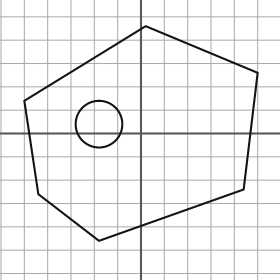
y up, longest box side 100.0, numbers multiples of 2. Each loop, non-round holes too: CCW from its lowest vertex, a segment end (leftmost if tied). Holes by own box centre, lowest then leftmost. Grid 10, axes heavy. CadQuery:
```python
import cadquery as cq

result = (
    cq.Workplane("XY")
    .moveTo(-18.0, -46.0)
    .lineTo(44.0, -24.0)
    .lineTo(50.0, 26.0)
    .lineTo(2.0, 46.0)
    .lineTo(-50.0, 14.0)
    .lineTo(-44.0, -26.0)
    .close()
    .moveTo(-18.0, 4.0)
    .circle(10.0)
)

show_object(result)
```